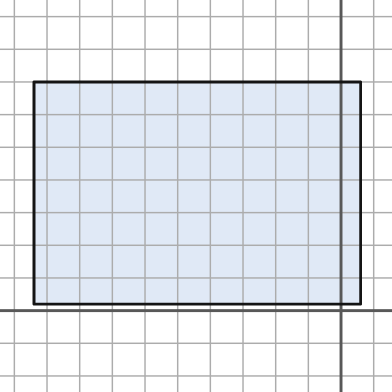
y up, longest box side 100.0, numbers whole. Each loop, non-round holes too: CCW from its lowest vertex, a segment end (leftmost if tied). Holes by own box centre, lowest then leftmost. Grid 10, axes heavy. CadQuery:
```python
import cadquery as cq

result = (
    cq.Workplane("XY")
    .moveTo(-94.0, 2.0)
    .lineTo(6.0, 2.0)
    .lineTo(6.0, 70.0)
    .lineTo(-94.0, 70.0)
    .close()
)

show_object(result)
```